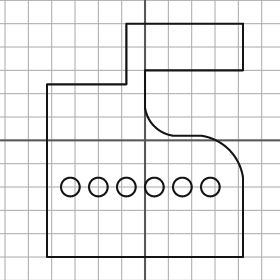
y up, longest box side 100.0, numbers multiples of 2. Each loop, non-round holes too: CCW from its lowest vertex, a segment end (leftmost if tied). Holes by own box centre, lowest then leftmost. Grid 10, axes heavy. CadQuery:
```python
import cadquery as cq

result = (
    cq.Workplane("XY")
    .moveTo(-42.0, -50.0)
    .lineTo(42.0, -50.0)
    .lineTo(42.0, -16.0)
    .threePointArc((36.0, -4.0), (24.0, 2.0))
    .lineTo(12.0, 2.0)
    .threePointArc((4.0, 6.0), (0.0, 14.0))
    .lineTo(0.0, 30.0)
    .lineTo(42.0, 30.0)
    .lineTo(42.0, 50.0)
    .lineTo(-8.0, 50.0)
    .lineTo(-8.0, 24.0)
    .lineTo(-42.0, 24.0)
    .close()
    .moveTo(-32.0, -20.0)
    .circle(4.0)
    .moveTo(-20.0, -20.0)
    .circle(4.0)
    .moveTo(-8.0, -20.0)
    .circle(4.0)
    .moveTo(4.0, -20.0)
    .circle(4.0)
    .moveTo(16.0, -20.0)
    .circle(4.0)
    .moveTo(28.0, -20.0)
    .circle(4.0)
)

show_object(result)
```